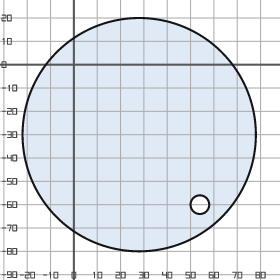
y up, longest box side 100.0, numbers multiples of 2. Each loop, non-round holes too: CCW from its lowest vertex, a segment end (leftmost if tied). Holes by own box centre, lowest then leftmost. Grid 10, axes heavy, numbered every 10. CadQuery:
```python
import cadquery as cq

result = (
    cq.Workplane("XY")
    .moveTo(28.0, -30.0)
    .circle(50.0)
    .moveTo(54.0, -60.0)
    .circle(4.0)
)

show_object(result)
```